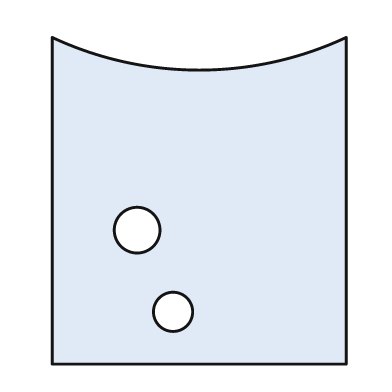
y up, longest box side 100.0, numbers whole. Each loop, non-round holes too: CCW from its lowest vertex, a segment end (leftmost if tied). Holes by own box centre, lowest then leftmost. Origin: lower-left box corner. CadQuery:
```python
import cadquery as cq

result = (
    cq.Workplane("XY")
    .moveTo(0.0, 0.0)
    .lineTo(90.0, 0.0)
    .lineTo(90.0, 100.0)
    .threePointArc((45.0, 90.0), (0.0, 100.0))
    .close()
    .moveTo(37.0, 16.0)
    .circle(6.0)
    .moveTo(26.0, 41.0)
    .circle(7.0)
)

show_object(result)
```